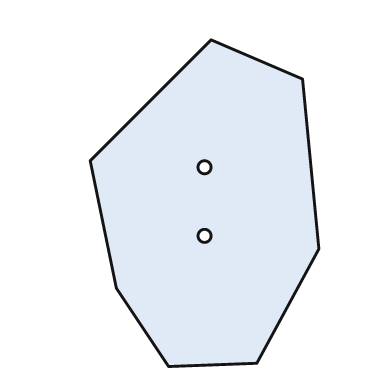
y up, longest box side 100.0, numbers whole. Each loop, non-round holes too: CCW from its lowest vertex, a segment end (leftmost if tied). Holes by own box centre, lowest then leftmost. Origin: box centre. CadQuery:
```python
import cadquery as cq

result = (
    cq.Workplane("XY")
    .moveTo(-11.0, -50.0)
    .lineTo(16.0, -49.0)
    .lineTo(35.0, -14.0)
    .lineTo(30.0, 38.0)
    .lineTo(2.0, 50.0)
    .lineTo(-35.0, 13.0)
    .lineTo(-27.0, -26.0)
    .close()
    .moveTo(0.0, -10.0)
    .circle(2.0)
    .moveTo(0.0, 11.0)
    .circle(2.0)
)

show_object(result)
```